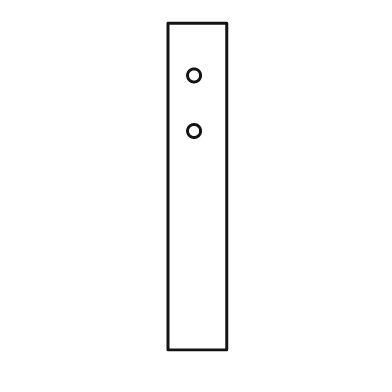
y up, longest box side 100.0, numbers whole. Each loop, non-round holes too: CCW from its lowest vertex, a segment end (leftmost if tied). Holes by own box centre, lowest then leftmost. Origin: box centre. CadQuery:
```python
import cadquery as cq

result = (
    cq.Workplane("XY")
    .moveTo(-9.0, -50.0)
    .lineTo(9.0, -50.0)
    .lineTo(9.0, 50.0)
    .lineTo(-9.0, 50.0)
    .close()
    .moveTo(-1.0, 17.0)
    .circle(2.0)
    .moveTo(-1.0, 34.0)
    .circle(2.0)
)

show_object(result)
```